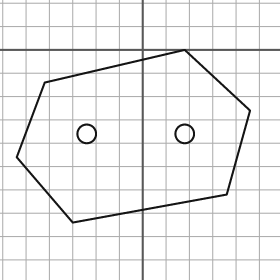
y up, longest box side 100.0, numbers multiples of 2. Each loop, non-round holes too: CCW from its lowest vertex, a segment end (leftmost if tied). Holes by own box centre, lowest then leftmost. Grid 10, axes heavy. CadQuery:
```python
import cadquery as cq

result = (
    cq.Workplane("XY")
    .moveTo(-30.0, -74.0)
    .lineTo(36.0, -62.0)
    .lineTo(46.0, -26.0)
    .lineTo(18.0, 0.0)
    .lineTo(-42.0, -14.0)
    .lineTo(-54.0, -46.0)
    .close()
    .moveTo(-24.0, -36.0)
    .circle(4.0)
    .moveTo(18.0, -36.0)
    .circle(4.0)
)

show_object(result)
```